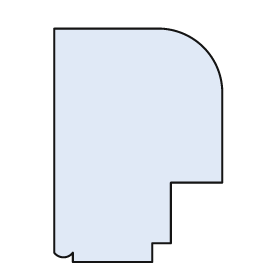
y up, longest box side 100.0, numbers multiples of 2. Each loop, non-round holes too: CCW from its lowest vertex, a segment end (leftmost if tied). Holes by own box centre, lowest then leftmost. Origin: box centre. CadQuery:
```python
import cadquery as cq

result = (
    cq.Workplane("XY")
    .moveTo(-28.0, -50.0)
    .lineTo(6.0, -50.0)
    .lineTo(6.0, -42.0)
    .lineTo(14.0, -42.0)
    .lineTo(14.0, -16.0)
    .lineTo(36.0, -16.0)
    .lineTo(36.0, 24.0)
    .threePointArc((28.0, 42.0), (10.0, 50.0))
    .lineTo(-36.0, 50.0)
    .lineTo(-36.0, -46.0)
    .threePointArc((-32.0, -48.0), (-28.0, -46.0))
    .close()
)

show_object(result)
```